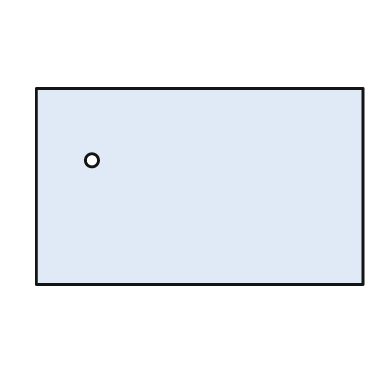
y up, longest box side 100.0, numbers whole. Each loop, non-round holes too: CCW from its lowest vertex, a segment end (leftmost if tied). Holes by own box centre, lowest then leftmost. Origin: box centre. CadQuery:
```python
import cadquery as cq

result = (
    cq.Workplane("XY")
    .moveTo(-50.0, -30.0)
    .lineTo(50.0, -30.0)
    .lineTo(50.0, 30.0)
    .lineTo(-50.0, 30.0)
    .close()
    .moveTo(-33.0, 8.0)
    .circle(2.0)
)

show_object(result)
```